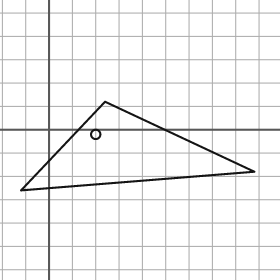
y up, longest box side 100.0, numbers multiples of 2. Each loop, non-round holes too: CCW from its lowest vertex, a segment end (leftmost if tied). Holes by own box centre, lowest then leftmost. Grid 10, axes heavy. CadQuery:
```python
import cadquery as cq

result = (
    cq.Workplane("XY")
    .moveTo(-12.0, -26.0)
    .lineTo(88.0, -18.0)
    .lineTo(24.0, 12.0)
    .close()
    .moveTo(20.0, -2.0)
    .circle(2.0)
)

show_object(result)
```